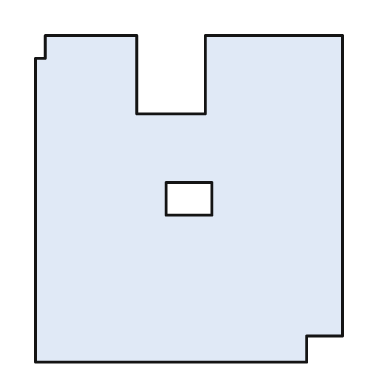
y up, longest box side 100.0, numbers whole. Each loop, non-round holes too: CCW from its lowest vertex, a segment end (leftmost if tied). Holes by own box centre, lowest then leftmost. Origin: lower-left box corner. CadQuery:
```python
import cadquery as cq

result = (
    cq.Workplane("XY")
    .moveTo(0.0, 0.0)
    .lineTo(83.0, 0.0)
    .lineTo(83.0, 8.0)
    .lineTo(94.0, 8.0)
    .lineTo(94.0, 100.0)
    .lineTo(52.0, 100.0)
    .lineTo(52.0, 76.0)
    .lineTo(31.0, 76.0)
    .lineTo(31.0, 100.0)
    .lineTo(3.0, 100.0)
    .lineTo(3.0, 93.0)
    .lineTo(0.0, 93.0)
    .close()
    .moveTo(40.0, 45.0)
    .lineTo(54.0, 45.0)
    .lineTo(54.0, 55.0)
    .lineTo(40.0, 55.0)
    .close()
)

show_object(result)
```